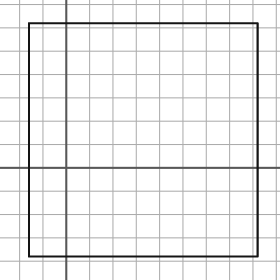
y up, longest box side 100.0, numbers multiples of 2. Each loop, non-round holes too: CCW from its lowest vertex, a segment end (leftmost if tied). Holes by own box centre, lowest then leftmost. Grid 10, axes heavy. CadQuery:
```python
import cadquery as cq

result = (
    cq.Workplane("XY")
    .moveTo(-16.0, -38.0)
    .lineTo(82.0, -38.0)
    .lineTo(82.0, 62.0)
    .lineTo(-16.0, 62.0)
    .close()
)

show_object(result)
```